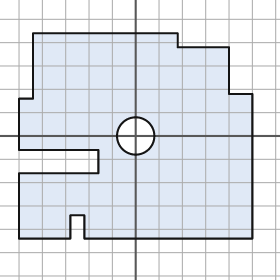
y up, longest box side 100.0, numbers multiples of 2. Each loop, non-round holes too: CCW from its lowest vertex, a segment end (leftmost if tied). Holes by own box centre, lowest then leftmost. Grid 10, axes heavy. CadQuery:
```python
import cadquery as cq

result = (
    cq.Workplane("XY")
    .moveTo(-50.0, -44.0)
    .lineTo(-28.0, -44.0)
    .lineTo(-28.0, -34.0)
    .lineTo(-22.0, -34.0)
    .lineTo(-22.0, -44.0)
    .lineTo(50.0, -44.0)
    .lineTo(50.0, 18.0)
    .lineTo(40.0, 18.0)
    .lineTo(40.0, 38.0)
    .lineTo(18.0, 38.0)
    .lineTo(18.0, 44.0)
    .lineTo(-44.0, 44.0)
    .lineTo(-44.0, 16.0)
    .lineTo(-50.0, 16.0)
    .lineTo(-50.0, -6.0)
    .lineTo(-16.0, -6.0)
    .lineTo(-16.0, -16.0)
    .lineTo(-50.0, -16.0)
    .close()
    .moveTo(0.0, 0.0)
    .circle(8.0)
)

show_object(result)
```